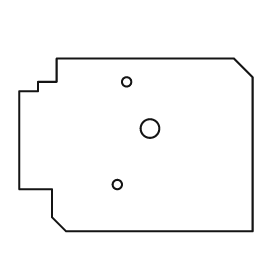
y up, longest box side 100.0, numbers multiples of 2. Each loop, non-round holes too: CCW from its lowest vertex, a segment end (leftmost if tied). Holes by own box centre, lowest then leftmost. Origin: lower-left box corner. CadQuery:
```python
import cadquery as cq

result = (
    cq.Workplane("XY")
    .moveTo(20.0, 0.0)
    .lineTo(100.0, 0.0)
    .lineTo(100.0, 66.0)
    .lineTo(92.0, 74.0)
    .lineTo(16.0, 74.0)
    .lineTo(16.0, 64.0)
    .lineTo(8.0, 64.0)
    .lineTo(8.0, 60.0)
    .lineTo(0.0, 60.0)
    .lineTo(0.0, 18.0)
    .lineTo(14.0, 18.0)
    .lineTo(14.0, 6.0)
    .close()
    .moveTo(42.0, 20.0)
    .circle(2.0)
    .moveTo(56.0, 44.0)
    .circle(4.0)
    .moveTo(46.0, 64.0)
    .circle(2.0)
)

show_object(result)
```